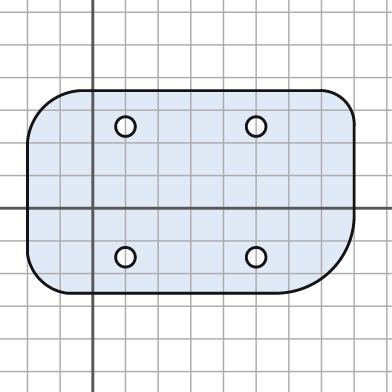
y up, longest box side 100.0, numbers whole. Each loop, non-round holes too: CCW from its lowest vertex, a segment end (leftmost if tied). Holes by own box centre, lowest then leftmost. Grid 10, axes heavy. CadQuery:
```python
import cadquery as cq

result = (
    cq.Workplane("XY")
    .moveTo(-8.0, -26.0)
    .lineTo(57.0, -26.0)
    .threePointArc((73.0, -19.0), (80.0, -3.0))
    .lineTo(80.0, 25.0)
    .threePointArc((77.0, 33.0), (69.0, 36.0))
    .lineTo(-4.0, 36.0)
    .threePointArc((-15.0, 31.0), (-20.0, 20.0))
    .lineTo(-20.0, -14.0)
    .threePointArc((-16.0, -22.0), (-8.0, -26.0))
    .close()
    .moveTo(10.0, -15.0)
    .circle(3.0)
    .moveTo(50.0, -15.0)
    .circle(3.0)
    .moveTo(10.0, 25.0)
    .circle(3.0)
    .moveTo(50.0, 25.0)
    .circle(3.0)
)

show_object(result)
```